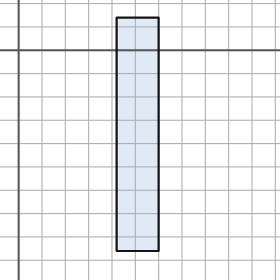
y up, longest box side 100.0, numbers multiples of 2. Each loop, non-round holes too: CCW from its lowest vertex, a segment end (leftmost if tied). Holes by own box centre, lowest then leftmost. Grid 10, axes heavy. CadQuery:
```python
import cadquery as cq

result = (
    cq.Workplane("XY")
    .moveTo(42.0, -86.0)
    .lineTo(60.0, -86.0)
    .lineTo(60.0, 14.0)
    .lineTo(42.0, 14.0)
    .close()
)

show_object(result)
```